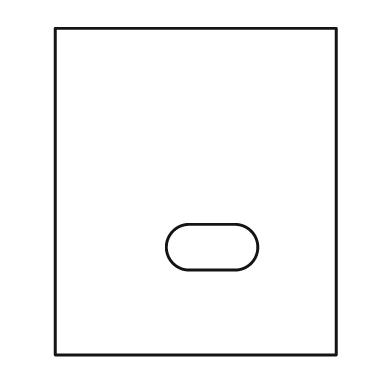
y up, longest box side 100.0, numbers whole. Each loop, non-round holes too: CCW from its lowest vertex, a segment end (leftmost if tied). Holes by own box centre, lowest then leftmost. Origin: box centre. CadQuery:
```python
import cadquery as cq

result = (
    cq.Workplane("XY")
    .moveTo(-43.0, -50.0)
    .lineTo(43.0, -50.0)
    .lineTo(43.0, 50.0)
    .lineTo(-43.0, 50.0)
    .close()
    .moveTo(-2.0, -24.0)
    .lineTo(12.0, -24.0)
    .threePointArc((19.0, -17.0), (12.0, -10.0))
    .lineTo(-2.0, -10.0)
    .threePointArc((-9.0, -17.0), (-2.0, -24.0))
    .close()
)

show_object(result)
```